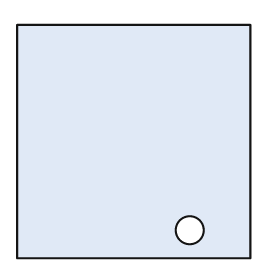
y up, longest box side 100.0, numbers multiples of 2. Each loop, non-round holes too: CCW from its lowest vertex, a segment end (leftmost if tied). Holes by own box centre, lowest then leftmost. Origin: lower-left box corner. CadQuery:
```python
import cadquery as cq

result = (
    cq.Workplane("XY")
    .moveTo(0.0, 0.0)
    .lineTo(100.0, 0.0)
    .lineTo(100.0, 100.0)
    .lineTo(0.0, 100.0)
    .close()
    .moveTo(74.0, 12.0)
    .circle(6.0)
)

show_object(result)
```